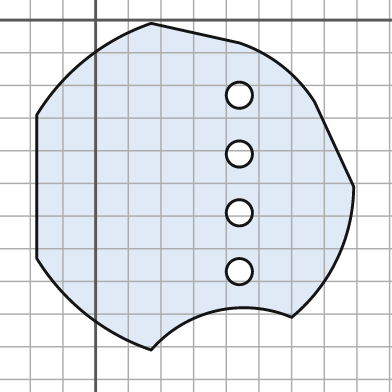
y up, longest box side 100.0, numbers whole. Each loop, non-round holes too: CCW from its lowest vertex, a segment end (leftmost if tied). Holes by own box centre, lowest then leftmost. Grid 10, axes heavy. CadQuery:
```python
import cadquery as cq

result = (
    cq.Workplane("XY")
    .moveTo(17.0, -101.0)
    .threePointArc((37.0, -89.0), (60.0, -91.0))
    .threePointArc((74.0, -73.0), (79.0, -51.0))
    .lineTo(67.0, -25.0)
    .threePointArc((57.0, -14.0), (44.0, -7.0))
    .lineTo(17.0, -1.0)
    .threePointArc((-3.0, -12.0), (-18.0, -29.0))
    .lineTo(-18.0, -73.0)
    .threePointArc((-3.0, -90.0), (17.0, -101.0))
    .close()
    .moveTo(44.0, -77.0)
    .circle(4.0)
    .moveTo(44.0, -59.0)
    .circle(4.0)
    .moveTo(44.0, -41.0)
    .circle(4.0)
    .moveTo(44.0, -23.0)
    .circle(4.0)
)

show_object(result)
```